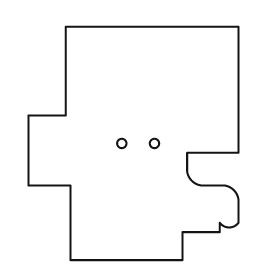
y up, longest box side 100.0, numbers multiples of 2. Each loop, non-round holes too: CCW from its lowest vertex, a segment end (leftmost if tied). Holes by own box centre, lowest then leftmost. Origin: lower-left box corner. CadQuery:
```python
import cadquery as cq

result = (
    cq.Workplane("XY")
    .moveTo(18.0, 0.0)
    .lineTo(66.0, 0.0)
    .lineTo(66.0, 12.0)
    .lineTo(82.0, 12.0)
    .lineTo(82.0, 16.0)
    .threePointArc((86.0, 14.0), (90.0, 16.0))
    .lineTo(90.0, 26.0)
    .threePointArc((88.0, 30.0), (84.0, 32.0))
    .lineTo(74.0, 32.0)
    .threePointArc((70.0, 34.0), (68.0, 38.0))
    .lineTo(68.0, 46.0)
    .lineTo(90.0, 46.0)
    .lineTo(90.0, 100.0)
    .lineTo(16.0, 100.0)
    .lineTo(16.0, 62.0)
    .lineTo(0.0, 62.0)
    .lineTo(0.0, 32.0)
    .lineTo(18.0, 32.0)
    .close()
    .moveTo(40.0, 50.0)
    .circle(2.0)
    .moveTo(54.0, 50.0)
    .circle(2.0)
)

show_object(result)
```